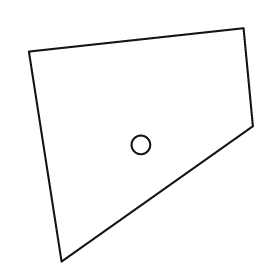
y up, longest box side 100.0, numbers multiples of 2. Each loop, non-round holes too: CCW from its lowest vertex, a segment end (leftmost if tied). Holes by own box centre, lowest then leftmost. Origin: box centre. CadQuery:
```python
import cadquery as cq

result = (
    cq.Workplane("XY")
    .moveTo(-34.0, -50.0)
    .lineTo(48.0, 8.0)
    .lineTo(44.0, 50.0)
    .lineTo(-48.0, 40.0)
    .close()
    .moveTo(0.0, 0.0)
    .circle(4.0)
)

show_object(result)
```